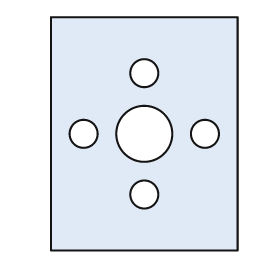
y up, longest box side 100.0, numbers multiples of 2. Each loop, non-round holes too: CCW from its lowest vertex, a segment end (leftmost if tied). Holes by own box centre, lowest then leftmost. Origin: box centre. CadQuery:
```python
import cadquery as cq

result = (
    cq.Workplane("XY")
    .moveTo(-40.0, -50.0)
    .lineTo(40.0, -50.0)
    .lineTo(40.0, 50.0)
    .lineTo(-40.0, 50.0)
    .close()
    .moveTo(0.0, -26.0)
    .circle(6.0)
    .moveTo(-26.0, 0.0)
    .circle(6.0)
    .moveTo(0.0, 0.0)
    .circle(12.0)
    .moveTo(26.0, 0.0)
    .circle(6.0)
    .moveTo(0.0, 26.0)
    .circle(6.0)
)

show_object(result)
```